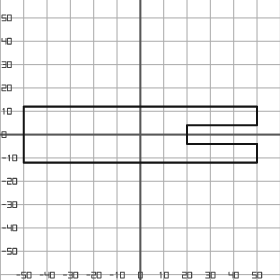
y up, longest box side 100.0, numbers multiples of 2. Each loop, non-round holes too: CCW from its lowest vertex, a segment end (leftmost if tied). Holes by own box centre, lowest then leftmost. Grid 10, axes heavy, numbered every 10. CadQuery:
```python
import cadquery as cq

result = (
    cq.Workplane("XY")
    .moveTo(-50.0, -12.0)
    .lineTo(50.0, -12.0)
    .lineTo(50.0, -4.0)
    .lineTo(20.0, -4.0)
    .lineTo(20.0, 4.0)
    .lineTo(50.0, 4.0)
    .lineTo(50.0, 12.0)
    .lineTo(-50.0, 12.0)
    .close()
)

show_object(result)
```